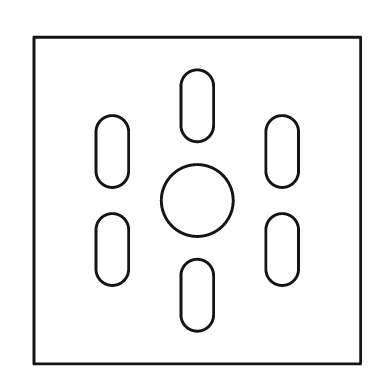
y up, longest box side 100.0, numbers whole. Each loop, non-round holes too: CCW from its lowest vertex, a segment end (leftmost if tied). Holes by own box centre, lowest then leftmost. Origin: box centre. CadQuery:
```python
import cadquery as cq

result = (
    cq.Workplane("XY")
    .moveTo(-50.0, -50.0)
    .lineTo(50.0, -50.0)
    .lineTo(50.0, 50.0)
    .lineTo(-50.0, 50.0)
    .close()
    .moveTo(-5.0, -35.0)
    .threePointArc((0.0, -40.0), (5.0, -35.0))
    .lineTo(5.0, -23.0)
    .threePointArc((0.0, -18.0), (-5.0, -23.0))
    .close()
    .moveTo(-31.0, -21.0)
    .threePointArc((-26.0, -26.0), (-21.0, -21.0))
    .lineTo(-21.0, -9.0)
    .threePointArc((-26.0, -4.0), (-31.0, -9.0))
    .close()
    .moveTo(21.0, -21.0)
    .threePointArc((26.0, -26.0), (31.0, -21.0))
    .lineTo(31.0, -9.0)
    .threePointArc((26.0, -4.0), (21.0, -9.0))
    .close()
    .moveTo(0.0, 0.0)
    .circle(11.0)
    .moveTo(-31.0, 9.0)
    .threePointArc((-26.0, 4.0), (-21.0, 9.0))
    .lineTo(-21.0, 21.0)
    .threePointArc((-26.0, 26.0), (-31.0, 21.0))
    .close()
    .moveTo(21.0, 9.0)
    .threePointArc((26.0, 4.0), (31.0, 9.0))
    .lineTo(31.0, 21.0)
    .threePointArc((26.0, 26.0), (21.0, 21.0))
    .close()
    .moveTo(-5.0, 23.0)
    .threePointArc((0.0, 18.0), (5.0, 23.0))
    .lineTo(5.0, 35.0)
    .threePointArc((0.0, 40.0), (-5.0, 35.0))
    .close()
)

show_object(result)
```